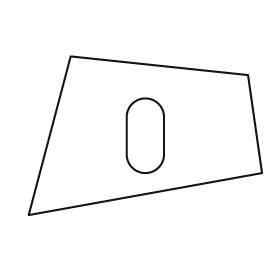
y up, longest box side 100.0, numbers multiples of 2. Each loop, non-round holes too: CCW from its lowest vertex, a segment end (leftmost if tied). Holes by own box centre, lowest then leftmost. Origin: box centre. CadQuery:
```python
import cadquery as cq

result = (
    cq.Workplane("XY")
    .moveTo(-50.0, -34.0)
    .lineTo(50.0, -16.0)
    .lineTo(44.0, 26.0)
    .lineTo(-32.0, 34.0)
    .close()
    .moveTo(-8.0, -8.0)
    .threePointArc((0.0, -16.0), (8.0, -8.0))
    .lineTo(8.0, 8.0)
    .threePointArc((0.0, 16.0), (-8.0, 8.0))
    .close()
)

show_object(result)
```